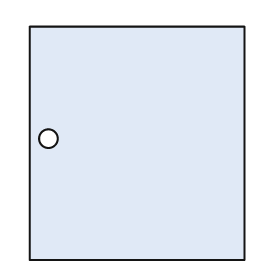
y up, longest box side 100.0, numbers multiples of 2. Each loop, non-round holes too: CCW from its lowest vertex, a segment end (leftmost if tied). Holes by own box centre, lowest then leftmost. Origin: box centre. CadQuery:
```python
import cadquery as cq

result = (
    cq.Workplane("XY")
    .moveTo(-46.0, -50.0)
    .lineTo(46.0, -50.0)
    .lineTo(46.0, 50.0)
    .lineTo(-46.0, 50.0)
    .close()
    .moveTo(-38.0, 2.0)
    .circle(4.0)
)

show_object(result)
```